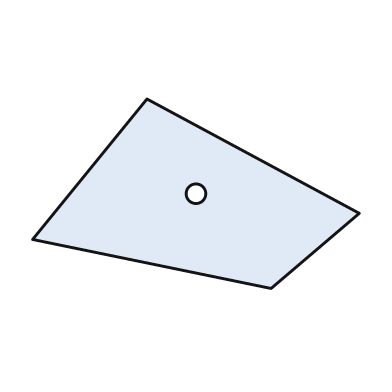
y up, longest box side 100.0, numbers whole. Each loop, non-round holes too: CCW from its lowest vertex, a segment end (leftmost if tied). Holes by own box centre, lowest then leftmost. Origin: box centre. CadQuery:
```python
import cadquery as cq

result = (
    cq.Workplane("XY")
    .moveTo(23.0, -29.0)
    .lineTo(50.0, -6.0)
    .lineTo(-15.0, 29.0)
    .lineTo(-50.0, -14.0)
    .close()
    .moveTo(0.0, 0.0)
    .circle(3.0)
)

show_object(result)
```